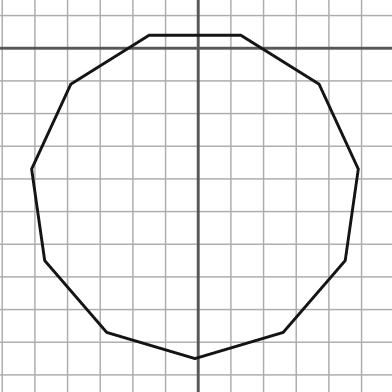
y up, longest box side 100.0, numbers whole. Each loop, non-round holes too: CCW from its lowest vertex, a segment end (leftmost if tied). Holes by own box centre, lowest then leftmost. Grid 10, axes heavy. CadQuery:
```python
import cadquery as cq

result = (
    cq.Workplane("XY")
    .moveTo(-1.0, -95.0)
    .lineTo(26.0, -87.0)
    .lineTo(45.0, -65.0)
    .lineTo(49.0, -37.0)
    .lineTo(37.0, -11.0)
    .lineTo(13.0, 4.0)
    .lineTo(-15.0, 4.0)
    .lineTo(-39.0, -11.0)
    .lineTo(-51.0, -37.0)
    .lineTo(-47.0, -65.0)
    .lineTo(-28.0, -87.0)
    .close()
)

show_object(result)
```